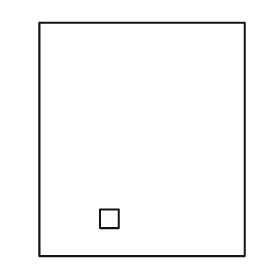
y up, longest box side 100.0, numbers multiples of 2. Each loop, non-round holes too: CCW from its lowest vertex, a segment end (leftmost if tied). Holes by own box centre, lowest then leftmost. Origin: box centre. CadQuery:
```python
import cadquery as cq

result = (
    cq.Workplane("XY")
    .moveTo(-44.0, -50.0)
    .lineTo(44.0, -50.0)
    .lineTo(44.0, 50.0)
    .lineTo(-44.0, 50.0)
    .close()
    .moveTo(-18.0, -38.0)
    .lineTo(-10.0, -38.0)
    .lineTo(-10.0, -30.0)
    .lineTo(-18.0, -30.0)
    .close()
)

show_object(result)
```